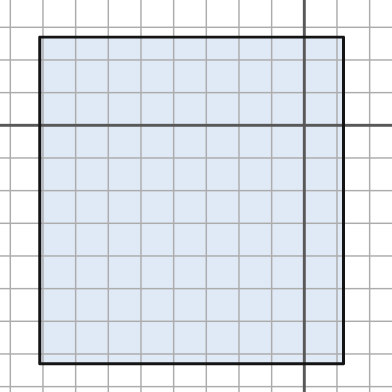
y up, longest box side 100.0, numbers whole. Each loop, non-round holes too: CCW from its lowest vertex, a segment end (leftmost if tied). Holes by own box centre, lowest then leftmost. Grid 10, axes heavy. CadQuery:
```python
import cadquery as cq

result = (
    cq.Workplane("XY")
    .moveTo(-81.0, -73.0)
    .lineTo(12.0, -73.0)
    .lineTo(12.0, 27.0)
    .lineTo(-81.0, 27.0)
    .close()
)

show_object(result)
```